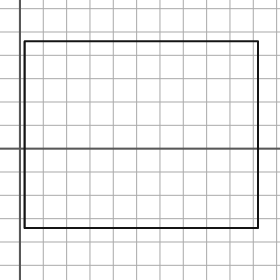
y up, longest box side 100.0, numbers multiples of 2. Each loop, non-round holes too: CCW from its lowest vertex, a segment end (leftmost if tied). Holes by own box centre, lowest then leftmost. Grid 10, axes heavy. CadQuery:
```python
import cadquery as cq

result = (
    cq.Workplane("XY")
    .moveTo(2.0, -34.0)
    .lineTo(102.0, -34.0)
    .lineTo(102.0, 46.0)
    .lineTo(2.0, 46.0)
    .close()
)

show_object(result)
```